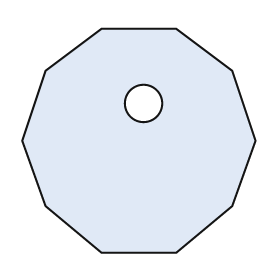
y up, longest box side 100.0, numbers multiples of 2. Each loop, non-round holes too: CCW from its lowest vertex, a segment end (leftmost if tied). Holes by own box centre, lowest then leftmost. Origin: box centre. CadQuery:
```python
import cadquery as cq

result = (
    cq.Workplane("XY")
    .moveTo(-16.0, -48.0)
    .lineTo(16.0, -48.0)
    .lineTo(40.0, -28.0)
    .lineTo(50.0, 0.0)
    .lineTo(40.0, 30.0)
    .lineTo(16.0, 48.0)
    .lineTo(-16.0, 48.0)
    .lineTo(-40.0, 30.0)
    .lineTo(-50.0, 0.0)
    .lineTo(-40.0, -28.0)
    .close()
    .moveTo(2.0, 16.0)
    .circle(8.0)
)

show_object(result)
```